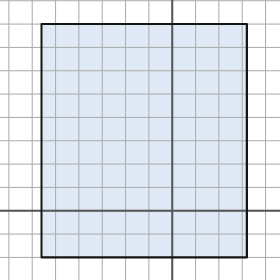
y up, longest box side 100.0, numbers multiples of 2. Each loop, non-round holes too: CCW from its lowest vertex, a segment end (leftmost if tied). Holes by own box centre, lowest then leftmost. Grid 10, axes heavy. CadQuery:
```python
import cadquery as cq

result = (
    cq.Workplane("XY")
    .moveTo(-56.0, -20.0)
    .lineTo(32.0, -20.0)
    .lineTo(32.0, 80.0)
    .lineTo(-56.0, 80.0)
    .close()
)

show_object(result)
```